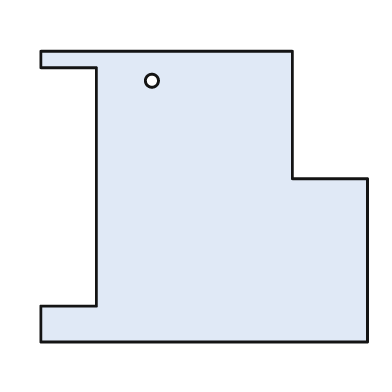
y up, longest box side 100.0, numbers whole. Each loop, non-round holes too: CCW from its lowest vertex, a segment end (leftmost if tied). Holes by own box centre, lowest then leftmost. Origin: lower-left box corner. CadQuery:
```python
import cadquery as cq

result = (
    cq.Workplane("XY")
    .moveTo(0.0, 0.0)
    .lineTo(100.0, 0.0)
    .lineTo(100.0, 50.0)
    .lineTo(77.0, 50.0)
    .lineTo(77.0, 89.0)
    .lineTo(0.0, 89.0)
    .lineTo(0.0, 84.0)
    .lineTo(17.0, 84.0)
    .lineTo(17.0, 11.0)
    .lineTo(0.0, 11.0)
    .close()
    .moveTo(34.0, 80.0)
    .circle(2.0)
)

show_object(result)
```